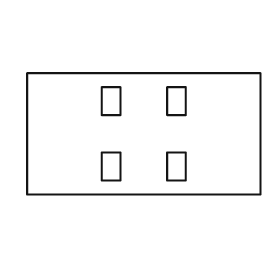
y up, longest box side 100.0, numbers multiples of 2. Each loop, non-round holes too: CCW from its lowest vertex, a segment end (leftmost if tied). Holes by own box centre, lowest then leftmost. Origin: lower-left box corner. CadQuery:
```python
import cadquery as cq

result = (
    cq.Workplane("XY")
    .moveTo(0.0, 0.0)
    .lineTo(100.0, 0.0)
    .lineTo(100.0, 52.0)
    .lineTo(0.0, 52.0)
    .close()
    .moveTo(32.0, 6.0)
    .lineTo(40.0, 6.0)
    .lineTo(40.0, 18.0)
    .lineTo(32.0, 18.0)
    .close()
    .moveTo(60.0, 6.0)
    .lineTo(68.0, 6.0)
    .lineTo(68.0, 18.0)
    .lineTo(60.0, 18.0)
    .close()
    .moveTo(32.0, 34.0)
    .lineTo(40.0, 34.0)
    .lineTo(40.0, 46.0)
    .lineTo(32.0, 46.0)
    .close()
    .moveTo(60.0, 34.0)
    .lineTo(68.0, 34.0)
    .lineTo(68.0, 46.0)
    .lineTo(60.0, 46.0)
    .close()
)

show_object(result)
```